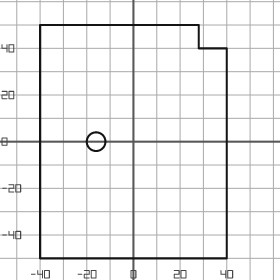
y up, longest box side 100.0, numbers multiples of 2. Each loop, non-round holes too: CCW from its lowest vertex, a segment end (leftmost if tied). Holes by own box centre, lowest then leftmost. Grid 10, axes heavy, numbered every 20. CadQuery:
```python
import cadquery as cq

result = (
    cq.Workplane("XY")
    .moveTo(-40.0, -50.0)
    .lineTo(40.0, -50.0)
    .lineTo(40.0, 40.0)
    .lineTo(28.0, 40.0)
    .lineTo(28.0, 50.0)
    .lineTo(-40.0, 50.0)
    .close()
    .moveTo(-16.0, 0.0)
    .circle(4.0)
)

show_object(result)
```